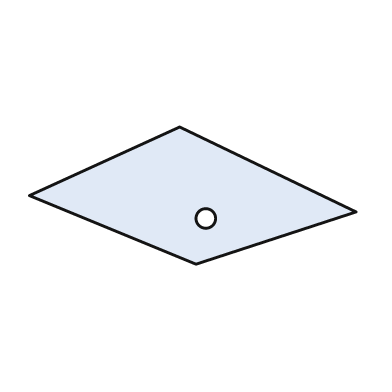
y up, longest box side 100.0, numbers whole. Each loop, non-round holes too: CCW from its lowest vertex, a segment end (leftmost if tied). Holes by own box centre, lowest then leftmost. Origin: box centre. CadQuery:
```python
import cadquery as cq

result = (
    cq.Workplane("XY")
    .moveTo(1.0, -21.0)
    .lineTo(50.0, -5.0)
    .lineTo(-4.0, 21.0)
    .lineTo(-50.0, 0.0)
    .close()
    .moveTo(4.0, -7.0)
    .circle(3.0)
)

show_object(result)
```